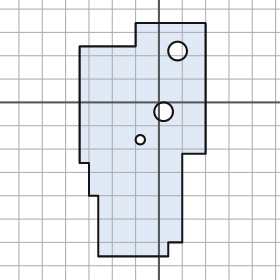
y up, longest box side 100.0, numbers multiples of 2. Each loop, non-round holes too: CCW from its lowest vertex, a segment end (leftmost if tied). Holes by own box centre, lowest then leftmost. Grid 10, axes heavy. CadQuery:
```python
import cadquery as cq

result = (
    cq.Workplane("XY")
    .moveTo(-26.0, -66.0)
    .lineTo(4.0, -66.0)
    .lineTo(4.0, -60.0)
    .lineTo(10.0, -60.0)
    .lineTo(10.0, -22.0)
    .lineTo(20.0, -22.0)
    .lineTo(20.0, 34.0)
    .lineTo(-10.0, 34.0)
    .lineTo(-10.0, 24.0)
    .lineTo(-34.0, 24.0)
    .lineTo(-34.0, -26.0)
    .lineTo(-30.0, -26.0)
    .lineTo(-30.0, -40.0)
    .lineTo(-26.0, -40.0)
    .close()
    .moveTo(-8.0, -16.0)
    .circle(2.0)
    .moveTo(2.0, -4.0)
    .circle(4.0)
    .moveTo(8.0, 22.0)
    .circle(4.0)
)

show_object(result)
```